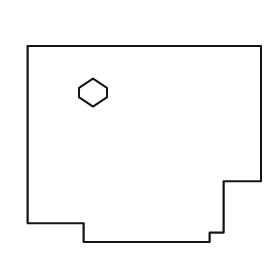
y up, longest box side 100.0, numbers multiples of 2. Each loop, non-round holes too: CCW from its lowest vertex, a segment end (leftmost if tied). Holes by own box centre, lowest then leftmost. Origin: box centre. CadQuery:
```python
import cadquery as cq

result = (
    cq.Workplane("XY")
    .moveTo(-26.0, -42.0)
    .lineTo(28.0, -42.0)
    .lineTo(28.0, -38.0)
    .lineTo(34.0, -38.0)
    .lineTo(34.0, -16.0)
    .lineTo(50.0, -16.0)
    .lineTo(50.0, 42.0)
    .lineTo(-50.0, 42.0)
    .lineTo(-50.0, -34.0)
    .lineTo(-26.0, -34.0)
    .close()
    .moveTo(-22.0, 16.0)
    .lineTo(-16.0, 20.0)
    .lineTo(-16.0, 24.0)
    .lineTo(-22.0, 28.0)
    .lineTo(-28.0, 24.0)
    .lineTo(-28.0, 20.0)
    .close()
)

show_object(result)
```